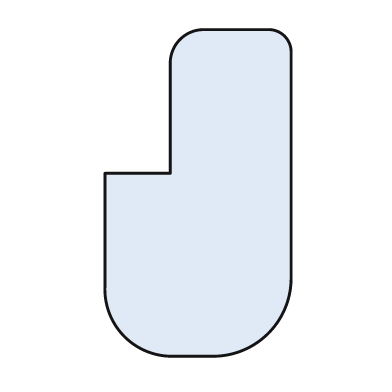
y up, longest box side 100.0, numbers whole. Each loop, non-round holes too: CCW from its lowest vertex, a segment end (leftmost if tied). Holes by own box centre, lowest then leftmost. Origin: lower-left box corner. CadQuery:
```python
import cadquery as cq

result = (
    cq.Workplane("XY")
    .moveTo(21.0, 0.0)
    .lineTo(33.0, 0.0)
    .threePointArc((50.0, 7.0), (57.0, 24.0))
    .lineTo(57.0, 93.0)
    .threePointArc((55.0, 98.0), (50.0, 100.0))
    .lineTo(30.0, 100.0)
    .threePointArc((23.0, 97.0), (20.0, 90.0))
    .lineTo(20.0, 56.0)
    .lineTo(0.0, 56.0)
    .lineTo(0.0, 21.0)
    .threePointArc((6.0, 6.0), (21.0, 0.0))
    .close()
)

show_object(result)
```